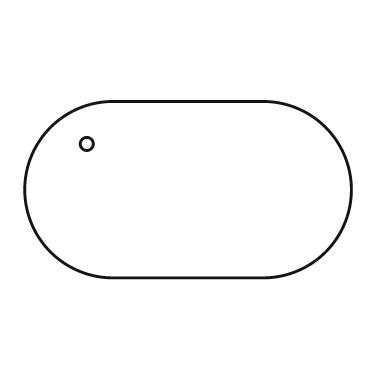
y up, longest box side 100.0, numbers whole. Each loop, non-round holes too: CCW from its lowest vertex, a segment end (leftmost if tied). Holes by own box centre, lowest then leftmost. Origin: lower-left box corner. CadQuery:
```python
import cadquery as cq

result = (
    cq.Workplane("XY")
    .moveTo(27.0, 0.0)
    .lineTo(73.0, 0.0)
    .threePointArc((100.0, 27.0), (73.0, 54.0))
    .lineTo(27.0, 54.0)
    .threePointArc((0.0, 27.0), (27.0, 0.0))
    .close()
    .moveTo(19.0, 41.0)
    .circle(2.0)
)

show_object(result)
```